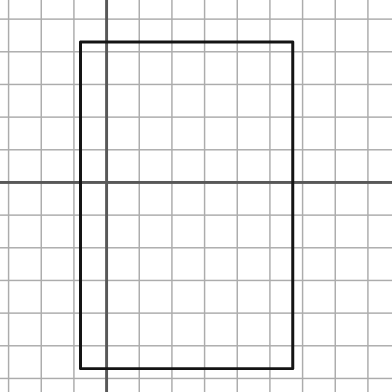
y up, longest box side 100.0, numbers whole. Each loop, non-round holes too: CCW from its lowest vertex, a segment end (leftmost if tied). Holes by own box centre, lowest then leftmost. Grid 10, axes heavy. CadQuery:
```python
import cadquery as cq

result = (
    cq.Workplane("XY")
    .moveTo(-8.0, -57.0)
    .lineTo(57.0, -57.0)
    .lineTo(57.0, 43.0)
    .lineTo(-8.0, 43.0)
    .close()
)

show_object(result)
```